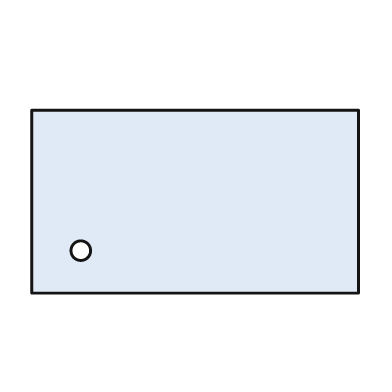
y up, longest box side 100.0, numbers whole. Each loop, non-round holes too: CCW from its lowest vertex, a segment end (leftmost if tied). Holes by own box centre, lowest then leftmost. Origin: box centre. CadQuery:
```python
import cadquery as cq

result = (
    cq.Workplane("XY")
    .moveTo(-50.0, -28.0)
    .lineTo(50.0, -28.0)
    .lineTo(50.0, 28.0)
    .lineTo(-50.0, 28.0)
    .close()
    .moveTo(-35.0, -15.0)
    .circle(3.0)
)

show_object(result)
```